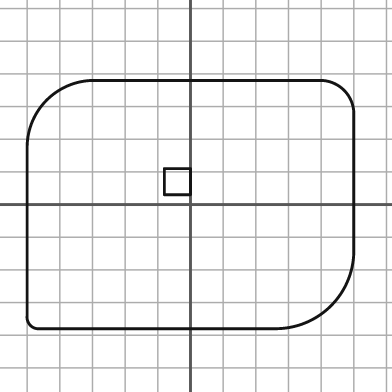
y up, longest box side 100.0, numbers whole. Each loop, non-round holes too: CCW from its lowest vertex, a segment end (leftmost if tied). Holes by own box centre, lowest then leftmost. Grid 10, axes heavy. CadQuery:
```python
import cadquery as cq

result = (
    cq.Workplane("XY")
    .moveTo(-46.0, -38.0)
    .lineTo(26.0, -38.0)
    .threePointArc((43.0, -31.0), (50.0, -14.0))
    .lineTo(50.0, 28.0)
    .threePointArc((47.0, 35.0), (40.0, 38.0))
    .lineTo(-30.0, 38.0)
    .threePointArc((-44.0, 32.0), (-50.0, 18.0))
    .lineTo(-50.0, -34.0)
    .threePointArc((-49.0, -37.0), (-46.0, -38.0))
    .close()
    .moveTo(-8.0, 3.0)
    .lineTo(0.0, 3.0)
    .lineTo(0.0, 11.0)
    .lineTo(-8.0, 11.0)
    .close()
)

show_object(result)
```